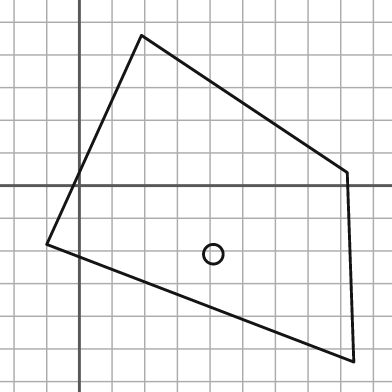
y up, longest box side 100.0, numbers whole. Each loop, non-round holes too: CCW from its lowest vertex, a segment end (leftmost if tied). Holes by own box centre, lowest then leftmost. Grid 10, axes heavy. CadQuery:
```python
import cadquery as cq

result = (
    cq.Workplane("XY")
    .moveTo(84.0, -54.0)
    .lineTo(82.0, 4.0)
    .lineTo(19.0, 46.0)
    .lineTo(-10.0, -18.0)
    .close()
    .moveTo(41.0, -21.0)
    .circle(3.0)
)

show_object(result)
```